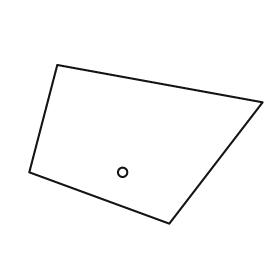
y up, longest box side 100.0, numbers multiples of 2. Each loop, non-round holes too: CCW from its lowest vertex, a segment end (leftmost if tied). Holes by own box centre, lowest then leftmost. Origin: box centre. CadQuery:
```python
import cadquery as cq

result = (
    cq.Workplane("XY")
    .moveTo(10.0, -34.0)
    .lineTo(50.0, 18.0)
    .lineTo(-38.0, 34.0)
    .lineTo(-50.0, -12.0)
    .close()
    .moveTo(-10.0, -12.0)
    .circle(2.0)
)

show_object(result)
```